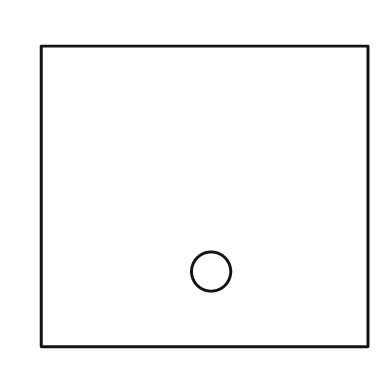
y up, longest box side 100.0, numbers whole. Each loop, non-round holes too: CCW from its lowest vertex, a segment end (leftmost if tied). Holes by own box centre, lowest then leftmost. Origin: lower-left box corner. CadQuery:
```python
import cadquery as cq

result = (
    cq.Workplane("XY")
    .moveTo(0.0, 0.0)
    .lineTo(100.0, 0.0)
    .lineTo(100.0, 92.0)
    .lineTo(0.0, 92.0)
    .close()
    .moveTo(52.0, 23.0)
    .circle(6.0)
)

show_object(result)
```